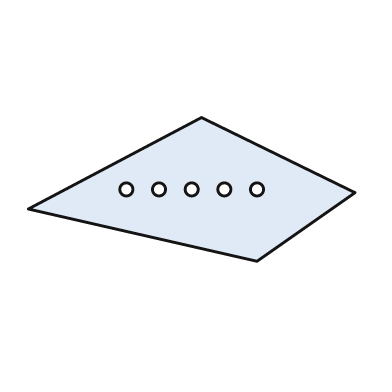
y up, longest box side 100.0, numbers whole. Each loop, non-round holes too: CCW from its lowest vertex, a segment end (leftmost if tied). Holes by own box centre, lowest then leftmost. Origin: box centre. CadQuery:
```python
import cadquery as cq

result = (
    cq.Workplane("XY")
    .moveTo(20.0, -22.0)
    .lineTo(50.0, -1.0)
    .lineTo(3.0, 22.0)
    .lineTo(-50.0, -6.0)
    .close()
    .moveTo(-20.0, 0.0)
    .circle(2.0)
    .moveTo(-10.0, 0.0)
    .circle(2.0)
    .moveTo(0.0, 0.0)
    .circle(2.0)
    .moveTo(10.0, 0.0)
    .circle(2.0)
    .moveTo(20.0, 0.0)
    .circle(2.0)
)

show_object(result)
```